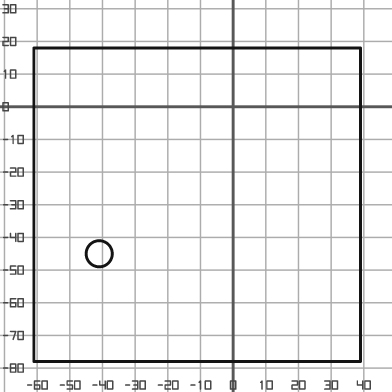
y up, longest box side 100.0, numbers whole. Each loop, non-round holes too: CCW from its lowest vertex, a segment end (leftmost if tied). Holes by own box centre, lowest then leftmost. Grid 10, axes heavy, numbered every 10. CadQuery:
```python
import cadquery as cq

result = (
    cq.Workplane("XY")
    .moveTo(-61.0, -78.0)
    .lineTo(39.0, -78.0)
    .lineTo(39.0, 18.0)
    .lineTo(-61.0, 18.0)
    .close()
    .moveTo(-41.0, -45.0)
    .circle(4.0)
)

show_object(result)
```